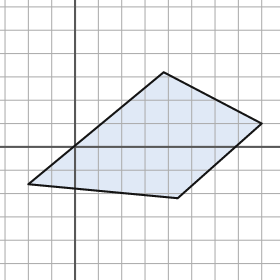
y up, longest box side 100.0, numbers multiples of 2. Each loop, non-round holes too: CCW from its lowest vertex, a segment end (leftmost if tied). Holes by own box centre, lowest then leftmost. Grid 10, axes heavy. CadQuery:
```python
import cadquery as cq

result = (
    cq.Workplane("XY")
    .moveTo(44.0, -22.0)
    .lineTo(80.0, 10.0)
    .lineTo(38.0, 32.0)
    .lineTo(-20.0, -16.0)
    .close()
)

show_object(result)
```